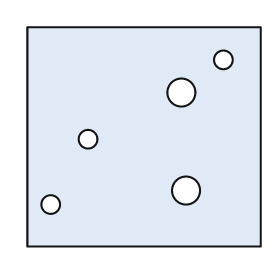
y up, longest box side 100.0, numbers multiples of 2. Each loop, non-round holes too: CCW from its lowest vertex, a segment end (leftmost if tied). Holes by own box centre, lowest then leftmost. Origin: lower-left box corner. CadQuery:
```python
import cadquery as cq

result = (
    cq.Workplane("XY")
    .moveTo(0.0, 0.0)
    .lineTo(100.0, 0.0)
    .lineTo(100.0, 94.0)
    .lineTo(0.0, 94.0)
    .close()
    .moveTo(10.0, 18.0)
    .circle(4.0)
    .moveTo(68.0, 24.0)
    .circle(6.0)
    .moveTo(26.0, 46.0)
    .circle(4.0)
    .moveTo(66.0, 66.0)
    .circle(6.0)
    .moveTo(84.0, 80.0)
    .circle(4.0)
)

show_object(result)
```